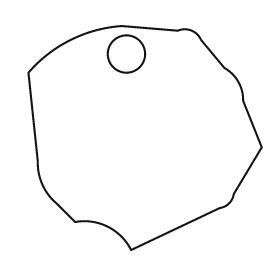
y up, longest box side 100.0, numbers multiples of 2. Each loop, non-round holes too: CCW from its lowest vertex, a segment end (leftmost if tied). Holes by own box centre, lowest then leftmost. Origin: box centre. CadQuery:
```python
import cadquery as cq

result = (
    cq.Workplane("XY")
    .moveTo(-6.0, -48.0)
    .lineTo(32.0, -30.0)
    .threePointArc((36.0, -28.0), (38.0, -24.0))
    .lineTo(50.0, -4.0)
    .lineTo(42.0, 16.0)
    .threePointArc((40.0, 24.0), (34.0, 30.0))
    .lineTo(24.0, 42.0)
    .threePointArc((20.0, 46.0), (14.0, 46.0))
    .lineTo(-10.0, 48.0)
    .threePointArc((-32.0, 42.0), (-50.0, 28.0))
    .lineTo(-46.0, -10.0)
    .threePointArc((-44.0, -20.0), (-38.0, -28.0))
    .lineTo(-30.0, -36.0)
    .threePointArc((-16.0, -38.0), (-6.0, -48.0))
    .close()
    .moveTo(-8.0, 36.0)
    .circle(8.0)
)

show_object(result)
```